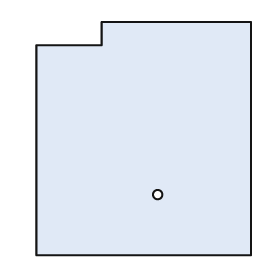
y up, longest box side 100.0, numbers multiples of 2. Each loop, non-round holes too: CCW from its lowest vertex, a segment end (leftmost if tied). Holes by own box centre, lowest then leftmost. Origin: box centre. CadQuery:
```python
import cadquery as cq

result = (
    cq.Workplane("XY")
    .moveTo(-46.0, -50.0)
    .lineTo(46.0, -50.0)
    .lineTo(46.0, 50.0)
    .lineTo(-18.0, 50.0)
    .lineTo(-18.0, 40.0)
    .lineTo(-46.0, 40.0)
    .close()
    .moveTo(6.0, -24.0)
    .circle(2.0)
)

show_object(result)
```